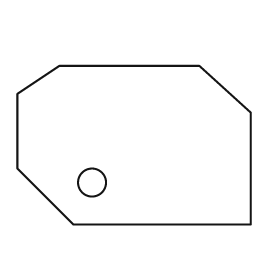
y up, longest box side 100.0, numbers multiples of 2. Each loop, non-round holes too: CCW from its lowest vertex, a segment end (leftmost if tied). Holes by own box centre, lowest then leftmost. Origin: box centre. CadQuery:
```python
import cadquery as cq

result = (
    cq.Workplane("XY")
    .moveTo(-26.0, -34.0)
    .lineTo(50.0, -34.0)
    .lineTo(50.0, 14.0)
    .lineTo(28.0, 34.0)
    .lineTo(-32.0, 34.0)
    .lineTo(-50.0, 22.0)
    .lineTo(-50.0, -10.0)
    .close()
    .moveTo(-18.0, -16.0)
    .circle(6.0)
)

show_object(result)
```